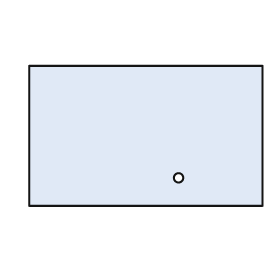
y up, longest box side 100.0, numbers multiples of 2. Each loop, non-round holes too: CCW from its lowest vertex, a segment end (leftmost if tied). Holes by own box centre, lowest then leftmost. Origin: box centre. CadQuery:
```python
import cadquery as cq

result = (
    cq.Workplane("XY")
    .moveTo(-50.0, -30.0)
    .lineTo(50.0, -30.0)
    .lineTo(50.0, 30.0)
    .lineTo(-50.0, 30.0)
    .close()
    .moveTo(14.0, -18.0)
    .circle(2.0)
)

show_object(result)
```